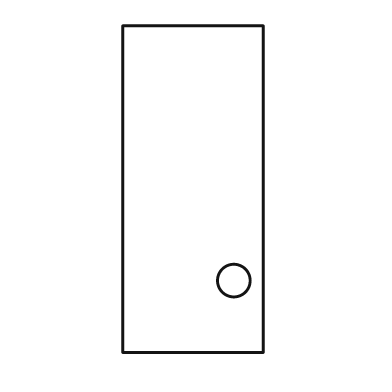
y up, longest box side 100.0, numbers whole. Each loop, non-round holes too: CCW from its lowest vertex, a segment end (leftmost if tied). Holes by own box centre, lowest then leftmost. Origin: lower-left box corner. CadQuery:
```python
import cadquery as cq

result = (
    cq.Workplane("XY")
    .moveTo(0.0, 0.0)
    .lineTo(43.0, 0.0)
    .lineTo(43.0, 100.0)
    .lineTo(0.0, 100.0)
    .close()
    .moveTo(34.0, 22.0)
    .circle(5.0)
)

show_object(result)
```